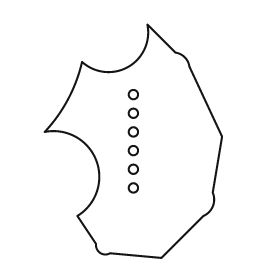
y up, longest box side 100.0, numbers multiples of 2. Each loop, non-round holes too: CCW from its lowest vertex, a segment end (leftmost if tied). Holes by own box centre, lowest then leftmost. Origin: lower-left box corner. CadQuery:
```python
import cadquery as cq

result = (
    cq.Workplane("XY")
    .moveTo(50.0, 0.0)
    .lineTo(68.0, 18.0)
    .threePointArc((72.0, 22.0), (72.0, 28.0))
    .lineTo(76.0, 52.0)
    .lineTo(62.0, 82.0)
    .threePointArc((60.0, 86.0), (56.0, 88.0))
    .lineTo(44.0, 100.0)
    .threePointArc((36.0, 82.0), (16.0, 84.0))
    .threePointArc((10.0, 68.0), (0.0, 54.0))
    .threePointArc((22.0, 42.0), (14.0, 18.0))
    .lineTo(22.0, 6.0)
    .threePointArc((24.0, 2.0), (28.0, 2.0))
    .close()
    .moveTo(38.0, 30.0)
    .circle(2.0)
    .moveTo(38.0, 38.0)
    .circle(2.0)
    .moveTo(38.0, 46.0)
    .circle(2.0)
    .moveTo(38.0, 54.0)
    .circle(2.0)
    .moveTo(38.0, 62.0)
    .circle(2.0)
    .moveTo(38.0, 70.0)
    .circle(2.0)
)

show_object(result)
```